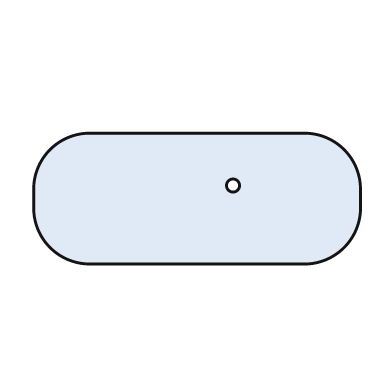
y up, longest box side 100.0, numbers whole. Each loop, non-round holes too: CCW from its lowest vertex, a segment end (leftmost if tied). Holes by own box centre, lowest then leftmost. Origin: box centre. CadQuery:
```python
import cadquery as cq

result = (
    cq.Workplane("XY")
    .moveTo(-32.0, -20.0)
    .lineTo(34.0, -20.0)
    .threePointArc((45.0, -15.0), (50.0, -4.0))
    .lineTo(50.0, 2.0)
    .threePointArc((45.0, 15.0), (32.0, 20.0))
    .lineTo(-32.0, 20.0)
    .threePointArc((-45.0, 15.0), (-50.0, 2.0))
    .lineTo(-50.0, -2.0)
    .threePointArc((-45.0, -15.0), (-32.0, -20.0))
    .close()
    .moveTo(11.0, 4.0)
    .circle(2.0)
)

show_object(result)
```